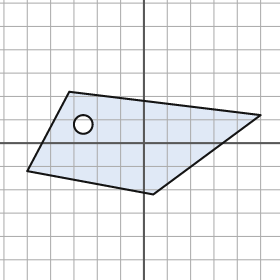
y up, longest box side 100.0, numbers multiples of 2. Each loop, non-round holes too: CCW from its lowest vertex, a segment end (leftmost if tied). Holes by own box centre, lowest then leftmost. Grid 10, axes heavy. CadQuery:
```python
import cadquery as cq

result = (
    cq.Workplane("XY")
    .moveTo(4.0, -22.0)
    .lineTo(50.0, 12.0)
    .lineTo(-32.0, 22.0)
    .lineTo(-50.0, -12.0)
    .close()
    .moveTo(-26.0, 8.0)
    .circle(4.0)
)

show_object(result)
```